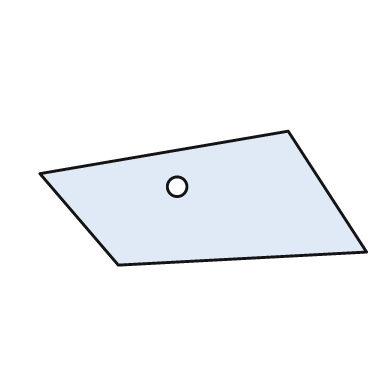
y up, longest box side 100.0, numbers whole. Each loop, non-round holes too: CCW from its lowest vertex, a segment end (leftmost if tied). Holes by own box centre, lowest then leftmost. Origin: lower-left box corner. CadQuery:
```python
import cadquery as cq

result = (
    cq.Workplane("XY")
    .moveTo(24.0, 0.0)
    .lineTo(100.0, 4.0)
    .lineTo(76.0, 41.0)
    .lineTo(0.0, 28.0)
    .close()
    .moveTo(42.0, 24.0)
    .circle(3.0)
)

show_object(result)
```